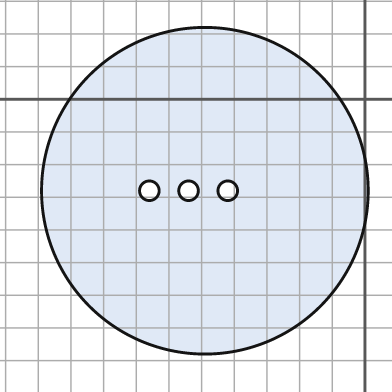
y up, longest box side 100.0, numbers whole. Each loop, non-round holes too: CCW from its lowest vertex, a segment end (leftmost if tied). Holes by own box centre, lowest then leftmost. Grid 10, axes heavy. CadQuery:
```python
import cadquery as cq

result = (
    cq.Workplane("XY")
    .moveTo(-49.0, -28.0)
    .circle(50.0)
    .moveTo(-66.0, -28.0)
    .circle(3.0)
    .moveTo(-54.0, -28.0)
    .circle(3.0)
    .moveTo(-42.0, -28.0)
    .circle(3.0)
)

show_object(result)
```